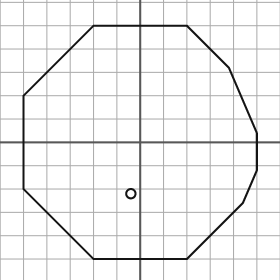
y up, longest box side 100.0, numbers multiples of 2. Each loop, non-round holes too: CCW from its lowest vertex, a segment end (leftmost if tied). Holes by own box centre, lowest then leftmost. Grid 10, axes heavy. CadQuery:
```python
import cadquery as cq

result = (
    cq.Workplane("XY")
    .moveTo(-20.0, -50.0)
    .lineTo(20.0, -50.0)
    .lineTo(44.0, -26.0)
    .lineTo(50.0, -12.0)
    .lineTo(50.0, 4.0)
    .lineTo(38.0, 32.0)
    .lineTo(20.0, 50.0)
    .lineTo(-20.0, 50.0)
    .lineTo(-50.0, 20.0)
    .lineTo(-50.0, -20.0)
    .close()
    .moveTo(-4.0, -22.0)
    .circle(2.0)
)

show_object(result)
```